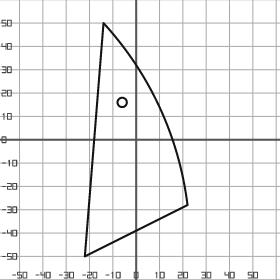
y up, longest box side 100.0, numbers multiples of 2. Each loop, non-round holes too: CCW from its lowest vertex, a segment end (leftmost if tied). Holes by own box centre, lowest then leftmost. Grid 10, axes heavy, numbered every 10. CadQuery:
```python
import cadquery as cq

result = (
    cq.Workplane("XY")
    .moveTo(-22.0, -50.0)
    .lineTo(22.0, -28.0)
    .threePointArc((10.0, 14.0), (-14.0, 50.0))
    .close()
    .moveTo(-6.0, 16.0)
    .circle(2.0)
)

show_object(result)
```